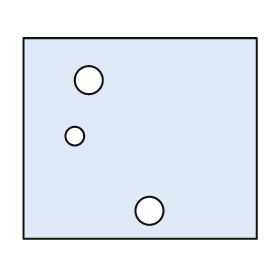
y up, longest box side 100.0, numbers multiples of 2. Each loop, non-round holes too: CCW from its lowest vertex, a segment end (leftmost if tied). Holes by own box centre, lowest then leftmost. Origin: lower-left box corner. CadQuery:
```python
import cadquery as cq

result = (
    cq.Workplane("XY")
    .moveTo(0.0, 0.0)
    .lineTo(100.0, 0.0)
    .lineTo(100.0, 86.0)
    .lineTo(0.0, 86.0)
    .close()
    .moveTo(54.0, 12.0)
    .circle(6.0)
    .moveTo(22.0, 44.0)
    .circle(4.0)
    .moveTo(28.0, 68.0)
    .circle(6.0)
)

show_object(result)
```